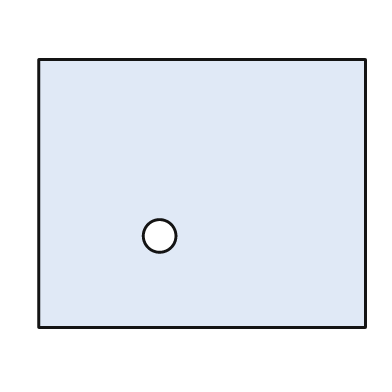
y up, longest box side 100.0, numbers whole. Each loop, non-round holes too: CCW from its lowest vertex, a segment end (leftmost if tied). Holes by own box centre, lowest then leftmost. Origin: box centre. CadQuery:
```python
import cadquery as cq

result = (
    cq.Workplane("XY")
    .moveTo(-50.0, -41.0)
    .lineTo(50.0, -41.0)
    .lineTo(50.0, 41.0)
    .lineTo(-50.0, 41.0)
    .close()
    .moveTo(-13.0, -13.0)
    .circle(5.0)
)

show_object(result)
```